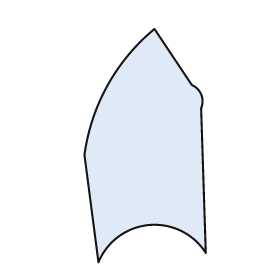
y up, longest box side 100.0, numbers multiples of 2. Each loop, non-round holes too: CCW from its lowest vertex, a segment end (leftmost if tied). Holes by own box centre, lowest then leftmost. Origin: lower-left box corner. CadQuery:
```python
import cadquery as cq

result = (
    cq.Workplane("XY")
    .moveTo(6.0, 0.0)
    .threePointArc((28.0, 16.0), (52.0, 4.0))
    .lineTo(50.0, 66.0)
    .threePointArc((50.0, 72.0), (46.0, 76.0))
    .lineTo(30.0, 100.0)
    .threePointArc((10.0, 76.0), (0.0, 46.0))
    .close()
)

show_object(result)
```